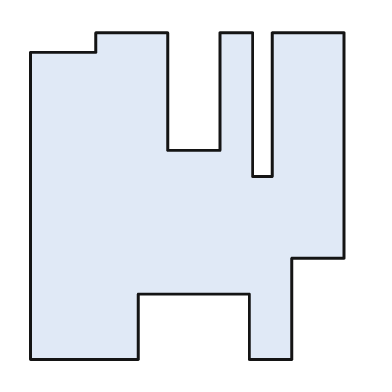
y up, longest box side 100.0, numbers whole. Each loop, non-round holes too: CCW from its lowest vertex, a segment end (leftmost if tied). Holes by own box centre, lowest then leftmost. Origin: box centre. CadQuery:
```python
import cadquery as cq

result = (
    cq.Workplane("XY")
    .moveTo(-48.0, -50.0)
    .lineTo(-15.0, -50.0)
    .lineTo(-15.0, -30.0)
    .lineTo(19.0, -30.0)
    .lineTo(19.0, -50.0)
    .lineTo(32.0, -50.0)
    .lineTo(32.0, -19.0)
    .lineTo(48.0, -19.0)
    .lineTo(48.0, 50.0)
    .lineTo(26.0, 50.0)
    .lineTo(26.0, 6.0)
    .lineTo(20.0, 6.0)
    .lineTo(20.0, 50.0)
    .lineTo(10.0, 50.0)
    .lineTo(10.0, 14.0)
    .lineTo(-6.0, 14.0)
    .lineTo(-6.0, 50.0)
    .lineTo(-28.0, 50.0)
    .lineTo(-28.0, 44.0)
    .lineTo(-48.0, 44.0)
    .close()
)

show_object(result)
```